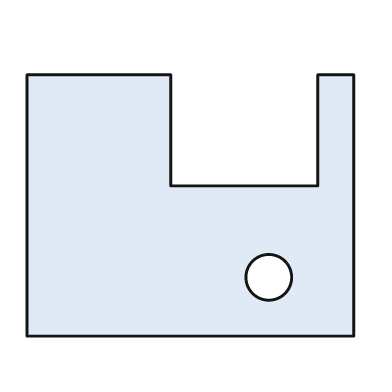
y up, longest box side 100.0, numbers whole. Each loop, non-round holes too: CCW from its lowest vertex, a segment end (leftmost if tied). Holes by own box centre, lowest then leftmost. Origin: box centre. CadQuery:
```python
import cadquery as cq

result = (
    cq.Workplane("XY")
    .moveTo(-50.0, -40.0)
    .lineTo(50.0, -40.0)
    .lineTo(50.0, 40.0)
    .lineTo(39.0, 40.0)
    .lineTo(39.0, 6.0)
    .lineTo(-6.0, 6.0)
    .lineTo(-6.0, 40.0)
    .lineTo(-50.0, 40.0)
    .close()
    .moveTo(24.0, -22.0)
    .circle(7.0)
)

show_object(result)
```